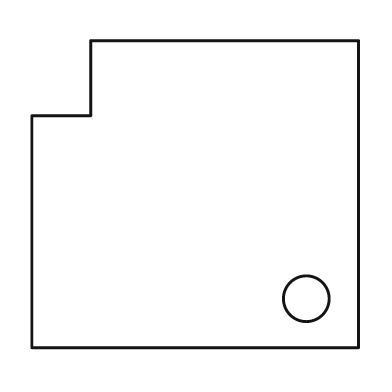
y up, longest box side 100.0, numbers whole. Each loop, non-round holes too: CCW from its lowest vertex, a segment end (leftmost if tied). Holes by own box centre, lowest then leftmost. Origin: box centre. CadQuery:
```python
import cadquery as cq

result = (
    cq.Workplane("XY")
    .moveTo(-50.0, -47.0)
    .lineTo(50.0, -47.0)
    .lineTo(50.0, 47.0)
    .lineTo(-32.0, 47.0)
    .lineTo(-32.0, 24.0)
    .lineTo(-50.0, 24.0)
    .close()
    .moveTo(34.0, -32.0)
    .circle(7.0)
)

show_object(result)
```